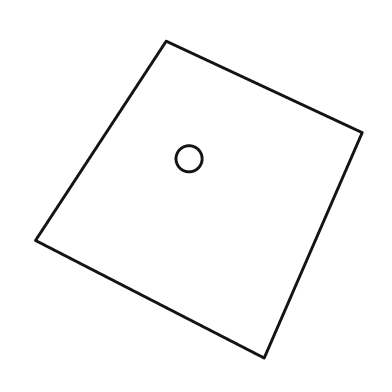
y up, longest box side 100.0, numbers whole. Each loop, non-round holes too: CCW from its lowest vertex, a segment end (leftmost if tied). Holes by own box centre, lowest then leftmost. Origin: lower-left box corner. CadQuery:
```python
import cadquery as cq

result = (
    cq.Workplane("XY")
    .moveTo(70.0, 0.0)
    .lineTo(100.0, 69.0)
    .lineTo(40.0, 97.0)
    .lineTo(0.0, 36.0)
    .close()
    .moveTo(47.0, 61.0)
    .circle(4.0)
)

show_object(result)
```